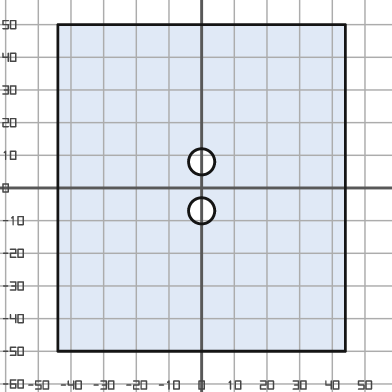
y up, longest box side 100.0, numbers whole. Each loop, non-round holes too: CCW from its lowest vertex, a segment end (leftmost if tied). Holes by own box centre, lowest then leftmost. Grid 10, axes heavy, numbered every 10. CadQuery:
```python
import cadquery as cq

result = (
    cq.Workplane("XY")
    .moveTo(-44.0, -50.0)
    .lineTo(44.0, -50.0)
    .lineTo(44.0, 50.0)
    .lineTo(-44.0, 50.0)
    .close()
    .moveTo(0.0, -7.0)
    .circle(4.0)
    .moveTo(0.0, 8.0)
    .circle(4.0)
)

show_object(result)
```